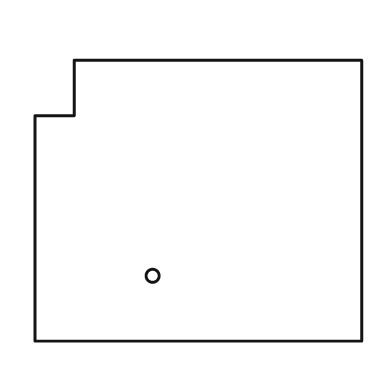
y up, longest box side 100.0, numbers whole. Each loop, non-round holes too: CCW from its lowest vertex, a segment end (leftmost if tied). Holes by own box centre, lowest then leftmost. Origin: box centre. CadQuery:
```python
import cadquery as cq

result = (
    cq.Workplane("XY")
    .moveTo(-50.0, -43.0)
    .lineTo(50.0, -43.0)
    .lineTo(50.0, 43.0)
    .lineTo(-38.0, 43.0)
    .lineTo(-38.0, 26.0)
    .lineTo(-50.0, 26.0)
    .close()
    .moveTo(-14.0, -23.0)
    .circle(2.0)
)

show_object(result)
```